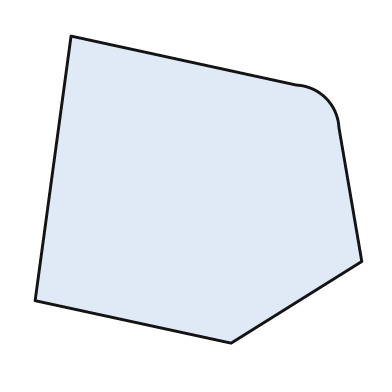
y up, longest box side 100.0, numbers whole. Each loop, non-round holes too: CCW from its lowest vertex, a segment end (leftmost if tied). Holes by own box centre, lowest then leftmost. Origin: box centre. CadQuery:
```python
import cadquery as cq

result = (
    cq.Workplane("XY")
    .moveTo(10.0, -47.0)
    .lineTo(50.0, -22.0)
    .lineTo(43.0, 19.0)
    .threePointArc((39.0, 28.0), (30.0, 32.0))
    .lineTo(-39.0, 47.0)
    .lineTo(-50.0, -34.0)
    .close()
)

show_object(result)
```